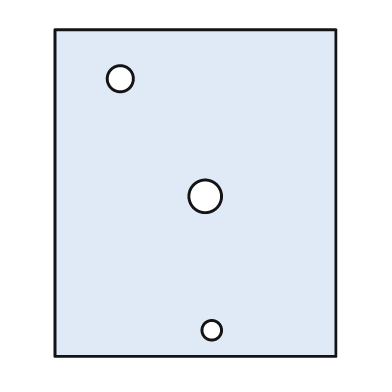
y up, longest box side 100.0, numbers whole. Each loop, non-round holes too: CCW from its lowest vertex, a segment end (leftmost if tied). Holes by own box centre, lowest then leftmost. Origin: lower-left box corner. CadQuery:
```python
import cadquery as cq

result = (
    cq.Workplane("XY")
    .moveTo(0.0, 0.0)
    .lineTo(86.0, 0.0)
    .lineTo(86.0, 100.0)
    .lineTo(0.0, 100.0)
    .close()
    .moveTo(48.0, 8.0)
    .circle(3.0)
    .moveTo(46.0, 49.0)
    .circle(5.0)
    .moveTo(20.0, 85.0)
    .circle(4.0)
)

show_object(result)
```